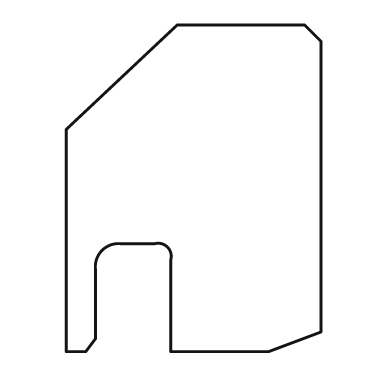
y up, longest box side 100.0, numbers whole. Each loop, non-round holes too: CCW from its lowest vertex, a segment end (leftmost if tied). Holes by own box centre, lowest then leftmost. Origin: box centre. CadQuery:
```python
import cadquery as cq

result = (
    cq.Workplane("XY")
    .moveTo(-39.0, -50.0)
    .lineTo(-33.0, -50.0)
    .lineTo(-30.0, -46.0)
    .lineTo(-30.0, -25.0)
    .threePointArc((-28.0, -19.0), (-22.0, -17.0))
    .lineTo(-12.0, -17.0)
    .threePointArc((-8.0, -18.0), (-7.0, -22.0))
    .lineTo(-7.0, -50.0)
    .lineTo(23.0, -50.0)
    .lineTo(39.0, -44.0)
    .lineTo(39.0, 45.0)
    .lineTo(34.0, 50.0)
    .lineTo(-5.0, 50.0)
    .lineTo(-39.0, 18.0)
    .close()
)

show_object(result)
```